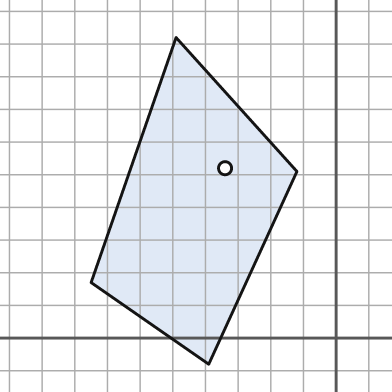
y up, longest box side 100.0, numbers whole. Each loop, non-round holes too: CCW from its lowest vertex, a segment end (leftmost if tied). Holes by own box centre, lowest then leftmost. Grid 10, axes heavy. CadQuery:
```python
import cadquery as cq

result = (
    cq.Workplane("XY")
    .moveTo(-39.0, -8.0)
    .lineTo(-12.0, 51.0)
    .lineTo(-49.0, 92.0)
    .lineTo(-75.0, 17.0)
    .close()
    .moveTo(-34.0, 52.0)
    .circle(2.0)
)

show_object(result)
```